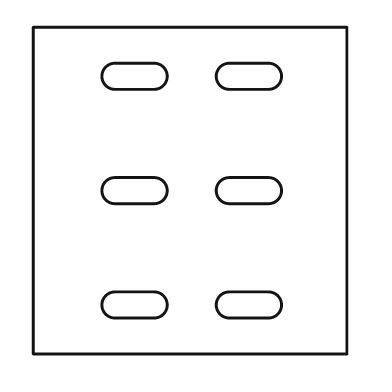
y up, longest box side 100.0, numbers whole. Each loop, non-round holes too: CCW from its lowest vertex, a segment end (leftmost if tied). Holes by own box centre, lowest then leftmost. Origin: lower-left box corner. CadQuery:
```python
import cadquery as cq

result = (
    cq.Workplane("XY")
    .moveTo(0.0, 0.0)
    .lineTo(96.0, 0.0)
    .lineTo(96.0, 100.0)
    .lineTo(0.0, 100.0)
    .close()
    .moveTo(25.0, 11.0)
    .lineTo(37.0, 11.0)
    .threePointArc((41.0, 15.0), (37.0, 19.0))
    .lineTo(25.0, 19.0)
    .threePointArc((21.0, 15.0), (25.0, 11.0))
    .close()
    .moveTo(60.0, 11.0)
    .lineTo(72.0, 11.0)
    .threePointArc((76.0, 15.0), (72.0, 19.0))
    .lineTo(60.0, 19.0)
    .threePointArc((56.0, 15.0), (60.0, 11.0))
    .close()
    .moveTo(25.0, 46.0)
    .lineTo(37.0, 46.0)
    .threePointArc((41.0, 50.0), (37.0, 54.0))
    .lineTo(25.0, 54.0)
    .threePointArc((21.0, 50.0), (25.0, 46.0))
    .close()
    .moveTo(60.0, 46.0)
    .lineTo(72.0, 46.0)
    .threePointArc((76.0, 50.0), (72.0, 54.0))
    .lineTo(60.0, 54.0)
    .threePointArc((56.0, 50.0), (60.0, 46.0))
    .close()
    .moveTo(25.0, 81.0)
    .lineTo(37.0, 81.0)
    .threePointArc((41.0, 85.0), (37.0, 89.0))
    .lineTo(25.0, 89.0)
    .threePointArc((21.0, 85.0), (25.0, 81.0))
    .close()
    .moveTo(60.0, 81.0)
    .lineTo(72.0, 81.0)
    .threePointArc((76.0, 85.0), (72.0, 89.0))
    .lineTo(60.0, 89.0)
    .threePointArc((56.0, 85.0), (60.0, 81.0))
    .close()
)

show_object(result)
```